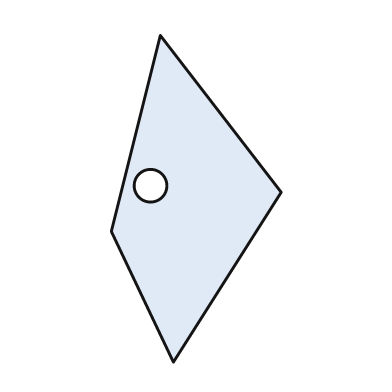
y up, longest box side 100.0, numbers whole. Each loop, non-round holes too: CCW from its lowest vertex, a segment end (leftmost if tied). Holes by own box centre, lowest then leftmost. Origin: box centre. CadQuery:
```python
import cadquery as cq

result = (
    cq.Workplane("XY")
    .moveTo(-7.0, -50.0)
    .lineTo(26.0, 2.0)
    .lineTo(-11.0, 50.0)
    .lineTo(-26.0, -10.0)
    .close()
    .moveTo(-14.0, 4.0)
    .circle(5.0)
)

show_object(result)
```